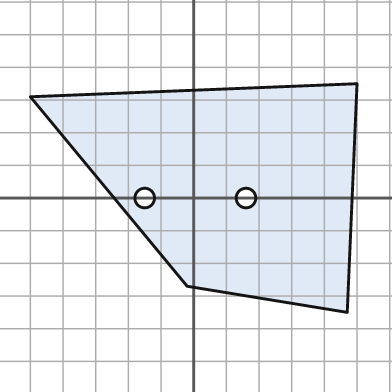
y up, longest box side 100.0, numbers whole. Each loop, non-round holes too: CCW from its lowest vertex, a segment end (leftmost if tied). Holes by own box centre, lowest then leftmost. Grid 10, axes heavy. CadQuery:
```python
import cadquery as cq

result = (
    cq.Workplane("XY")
    .moveTo(47.0, -35.0)
    .lineTo(50.0, 35.0)
    .lineTo(-50.0, 31.0)
    .lineTo(-2.0, -27.0)
    .close()
    .moveTo(-15.0, 0.0)
    .circle(3.0)
    .moveTo(16.0, 0.0)
    .circle(3.0)
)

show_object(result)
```